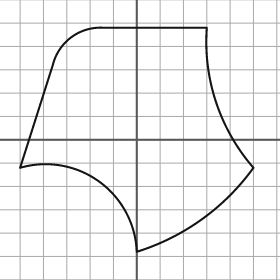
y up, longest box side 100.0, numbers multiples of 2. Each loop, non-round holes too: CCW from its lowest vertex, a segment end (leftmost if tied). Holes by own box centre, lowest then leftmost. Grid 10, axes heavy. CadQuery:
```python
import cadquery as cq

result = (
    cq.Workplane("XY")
    .moveTo(0.0, -48.0)
    .threePointArc((28.0, -34.0), (50.0, -12.0))
    .threePointArc((34.0, 16.0), (30.0, 48.0))
    .lineTo(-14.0, 48.0)
    .threePointArc((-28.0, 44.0), (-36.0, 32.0))
    .lineTo(-50.0, -12.0)
    .threePointArc((-16.0, -18.0), (0.0, -48.0))
    .close()
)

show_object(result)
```